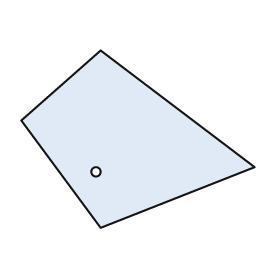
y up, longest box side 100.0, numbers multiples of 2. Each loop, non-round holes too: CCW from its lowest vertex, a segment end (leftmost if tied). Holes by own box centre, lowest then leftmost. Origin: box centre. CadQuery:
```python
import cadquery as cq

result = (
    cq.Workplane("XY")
    .moveTo(-16.0, -38.0)
    .lineTo(50.0, -12.0)
    .lineTo(-16.0, 38.0)
    .lineTo(-50.0, 8.0)
    .close()
    .moveTo(-18.0, -14.0)
    .circle(2.0)
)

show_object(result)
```